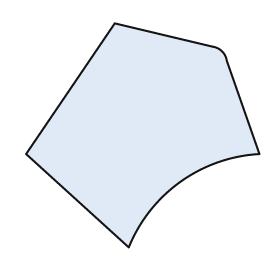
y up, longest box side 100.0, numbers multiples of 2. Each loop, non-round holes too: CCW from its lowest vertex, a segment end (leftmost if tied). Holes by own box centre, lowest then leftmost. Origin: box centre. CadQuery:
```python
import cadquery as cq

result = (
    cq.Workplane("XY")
    .moveTo(-6.0, -48.0)
    .threePointArc((16.0, -20.0), (50.0, -8.0))
    .lineTo(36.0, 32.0)
    .threePointArc((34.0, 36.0), (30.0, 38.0))
    .lineTo(-12.0, 48.0)
    .lineTo(-50.0, -8.0)
    .close()
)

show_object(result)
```